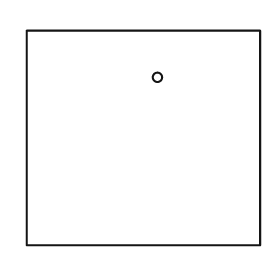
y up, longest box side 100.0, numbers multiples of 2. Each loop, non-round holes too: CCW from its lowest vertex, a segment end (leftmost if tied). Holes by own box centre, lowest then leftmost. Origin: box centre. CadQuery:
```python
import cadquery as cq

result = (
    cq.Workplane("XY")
    .moveTo(-50.0, -46.0)
    .lineTo(50.0, -46.0)
    .lineTo(50.0, 46.0)
    .lineTo(-50.0, 46.0)
    .close()
    .moveTo(6.0, 26.0)
    .circle(2.0)
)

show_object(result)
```